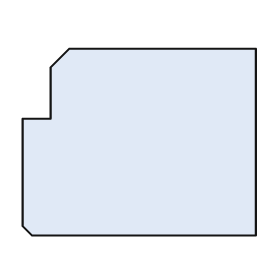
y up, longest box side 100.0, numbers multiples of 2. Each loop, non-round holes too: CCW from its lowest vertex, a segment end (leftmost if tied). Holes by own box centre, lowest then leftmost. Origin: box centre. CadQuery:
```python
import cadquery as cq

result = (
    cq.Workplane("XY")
    .moveTo(-46.0, -40.0)
    .lineTo(50.0, -40.0)
    .lineTo(50.0, 40.0)
    .lineTo(-30.0, 40.0)
    .lineTo(-38.0, 32.0)
    .lineTo(-38.0, 10.0)
    .lineTo(-50.0, 10.0)
    .lineTo(-50.0, -36.0)
    .close()
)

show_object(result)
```